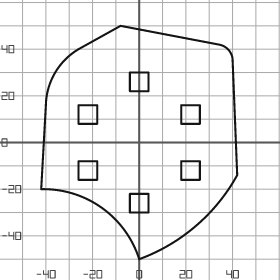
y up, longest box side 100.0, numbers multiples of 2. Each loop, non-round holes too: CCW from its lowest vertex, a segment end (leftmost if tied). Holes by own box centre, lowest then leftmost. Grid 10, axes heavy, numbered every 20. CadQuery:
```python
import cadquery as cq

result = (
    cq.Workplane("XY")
    .moveTo(0.0, -50.0)
    .threePointArc((24.0, -36.0), (42.0, -14.0))
    .lineTo(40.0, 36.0)
    .threePointArc((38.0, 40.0), (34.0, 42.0))
    .lineTo(-8.0, 50.0)
    .lineTo(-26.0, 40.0)
    .threePointArc((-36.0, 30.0), (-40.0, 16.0))
    .lineTo(-42.0, -20.0)
    .threePointArc((-16.0, -28.0), (0.0, -50.0))
    .close()
    .moveTo(-4.0, -30.0)
    .lineTo(4.0, -30.0)
    .lineTo(4.0, -22.0)
    .lineTo(-4.0, -22.0)
    .close()
    .moveTo(-26.0, -16.0)
    .lineTo(-18.0, -16.0)
    .lineTo(-18.0, -8.0)
    .lineTo(-26.0, -8.0)
    .close()
    .moveTo(18.0, -16.0)
    .lineTo(26.0, -16.0)
    .lineTo(26.0, -8.0)
    .lineTo(18.0, -8.0)
    .close()
    .moveTo(-26.0, 8.0)
    .lineTo(-18.0, 8.0)
    .lineTo(-18.0, 16.0)
    .lineTo(-26.0, 16.0)
    .close()
    .moveTo(18.0, 8.0)
    .lineTo(26.0, 8.0)
    .lineTo(26.0, 16.0)
    .lineTo(18.0, 16.0)
    .close()
    .moveTo(-4.0, 22.0)
    .lineTo(4.0, 22.0)
    .lineTo(4.0, 30.0)
    .lineTo(-4.0, 30.0)
    .close()
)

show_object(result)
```